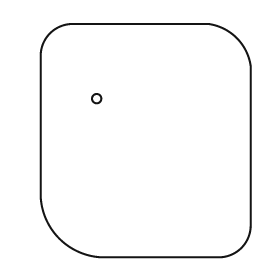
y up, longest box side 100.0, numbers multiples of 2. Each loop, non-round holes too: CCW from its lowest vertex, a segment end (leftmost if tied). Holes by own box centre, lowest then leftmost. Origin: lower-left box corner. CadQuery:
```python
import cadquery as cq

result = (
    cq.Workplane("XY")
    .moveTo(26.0, 0.0)
    .lineTo(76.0, 0.0)
    .threePointArc((86.0, 4.0), (90.0, 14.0))
    .lineTo(90.0, 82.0)
    .threePointArc((84.0, 94.0), (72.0, 100.0))
    .lineTo(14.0, 100.0)
    .threePointArc((4.0, 96.0), (0.0, 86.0))
    .lineTo(0.0, 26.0)
    .threePointArc((8.0, 8.0), (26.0, 0.0))
    .close()
    .moveTo(24.0, 68.0)
    .circle(2.0)
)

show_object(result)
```